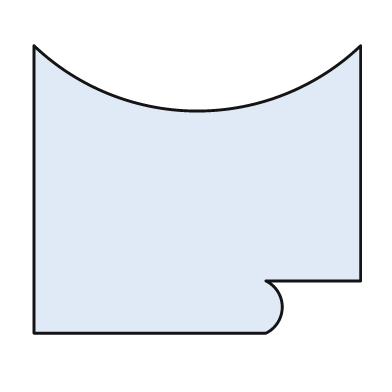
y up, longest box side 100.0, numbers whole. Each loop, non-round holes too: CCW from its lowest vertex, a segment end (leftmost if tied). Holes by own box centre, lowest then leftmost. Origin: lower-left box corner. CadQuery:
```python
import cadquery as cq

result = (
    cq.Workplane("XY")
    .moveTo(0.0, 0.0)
    .lineTo(71.0, 0.0)
    .threePointArc((76.0, 8.0), (71.0, 16.0))
    .lineTo(100.0, 16.0)
    .lineTo(100.0, 88.0)
    .threePointArc((50.0, 68.0), (0.0, 88.0))
    .close()
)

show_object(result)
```